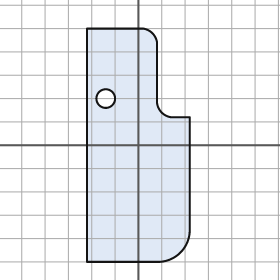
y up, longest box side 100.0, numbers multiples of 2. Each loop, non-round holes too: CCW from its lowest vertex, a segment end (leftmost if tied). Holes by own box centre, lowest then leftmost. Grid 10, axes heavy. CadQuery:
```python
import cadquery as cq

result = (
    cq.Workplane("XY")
    .moveTo(-22.0, -50.0)
    .lineTo(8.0, -50.0)
    .threePointArc((18.0, -46.0), (22.0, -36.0))
    .lineTo(22.0, 12.0)
    .lineTo(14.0, 12.0)
    .threePointArc((10.0, 14.0), (8.0, 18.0))
    .lineTo(8.0, 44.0)
    .threePointArc((6.0, 48.0), (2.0, 50.0))
    .lineTo(-22.0, 50.0)
    .close()
    .moveTo(-14.0, 20.0)
    .circle(4.0)
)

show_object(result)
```